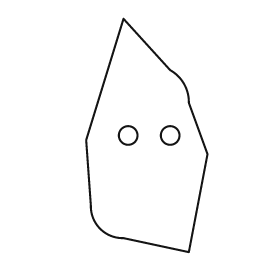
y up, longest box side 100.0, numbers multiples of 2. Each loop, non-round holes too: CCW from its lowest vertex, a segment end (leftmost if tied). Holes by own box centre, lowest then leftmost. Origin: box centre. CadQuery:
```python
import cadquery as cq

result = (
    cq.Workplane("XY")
    .moveTo(18.0, -50.0)
    .lineTo(26.0, -8.0)
    .lineTo(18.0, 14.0)
    .threePointArc((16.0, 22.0), (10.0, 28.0))
    .lineTo(-10.0, 50.0)
    .lineTo(-26.0, -2.0)
    .lineTo(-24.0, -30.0)
    .threePointArc((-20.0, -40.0), (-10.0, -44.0))
    .close()
    .moveTo(-8.0, 0.0)
    .circle(4.0)
    .moveTo(10.0, 0.0)
    .circle(4.0)
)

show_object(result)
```